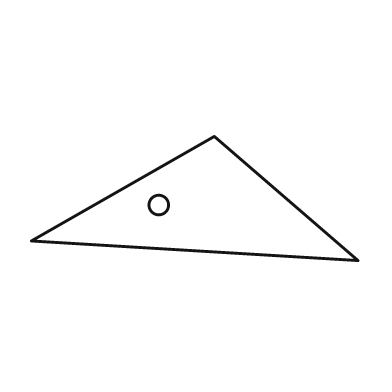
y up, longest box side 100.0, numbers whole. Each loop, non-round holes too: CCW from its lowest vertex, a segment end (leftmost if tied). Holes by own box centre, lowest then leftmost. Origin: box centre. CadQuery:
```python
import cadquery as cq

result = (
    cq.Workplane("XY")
    .moveTo(50.0, -19.0)
    .lineTo(6.0, 19.0)
    .lineTo(-50.0, -13.0)
    .close()
    .moveTo(-11.0, -2.0)
    .circle(3.0)
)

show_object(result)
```